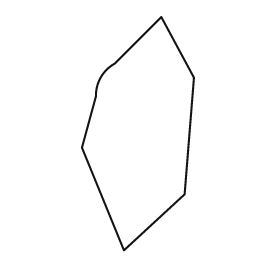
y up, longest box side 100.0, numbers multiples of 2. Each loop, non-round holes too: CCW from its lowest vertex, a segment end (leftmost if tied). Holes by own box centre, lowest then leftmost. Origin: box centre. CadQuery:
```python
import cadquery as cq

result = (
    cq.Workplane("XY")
    .moveTo(-6.0, -50.0)
    .lineTo(20.0, -26.0)
    .lineTo(24.0, 24.0)
    .lineTo(10.0, 50.0)
    .lineTo(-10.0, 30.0)
    .threePointArc((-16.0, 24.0), (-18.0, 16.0))
    .lineTo(-24.0, -6.0)
    .close()
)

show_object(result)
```